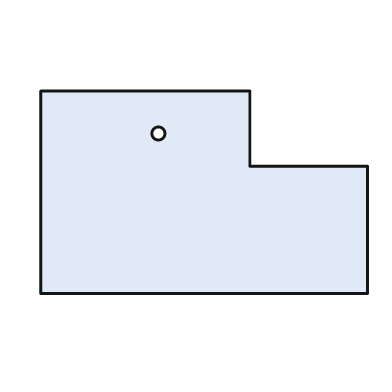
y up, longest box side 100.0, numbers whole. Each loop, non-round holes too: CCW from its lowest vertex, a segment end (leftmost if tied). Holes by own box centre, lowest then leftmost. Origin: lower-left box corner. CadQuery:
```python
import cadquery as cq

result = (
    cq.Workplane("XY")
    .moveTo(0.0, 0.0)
    .lineTo(100.0, 0.0)
    .lineTo(100.0, 39.0)
    .lineTo(64.0, 39.0)
    .lineTo(64.0, 62.0)
    .lineTo(0.0, 62.0)
    .close()
    .moveTo(36.0, 49.0)
    .circle(2.0)
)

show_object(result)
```